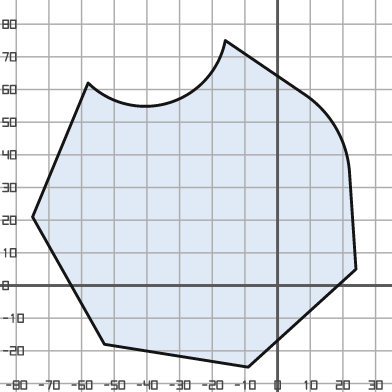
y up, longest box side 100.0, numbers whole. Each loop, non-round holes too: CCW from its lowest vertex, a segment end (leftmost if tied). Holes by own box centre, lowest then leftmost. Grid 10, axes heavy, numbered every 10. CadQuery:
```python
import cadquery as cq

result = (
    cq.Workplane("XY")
    .moveTo(-9.0, -25.0)
    .lineTo(24.0, 5.0)
    .lineTo(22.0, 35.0)
    .threePointArc((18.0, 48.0), (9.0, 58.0))
    .lineTo(-16.0, 75.0)
    .threePointArc((-33.0, 56.0), (-58.0, 62.0))
    .lineTo(-75.0, 21.0)
    .lineTo(-53.0, -18.0)
    .close()
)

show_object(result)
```